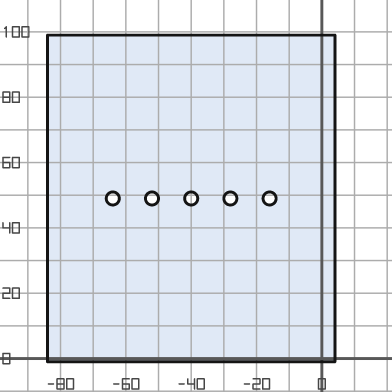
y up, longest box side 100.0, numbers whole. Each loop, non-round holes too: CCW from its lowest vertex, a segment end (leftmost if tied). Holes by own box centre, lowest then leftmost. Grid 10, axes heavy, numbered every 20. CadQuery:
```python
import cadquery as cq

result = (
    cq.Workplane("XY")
    .moveTo(-84.0, -1.0)
    .lineTo(4.0, -1.0)
    .lineTo(4.0, 99.0)
    .lineTo(-84.0, 99.0)
    .close()
    .moveTo(-64.0, 49.0)
    .circle(2.0)
    .moveTo(-52.0, 49.0)
    .circle(2.0)
    .moveTo(-40.0, 49.0)
    .circle(2.0)
    .moveTo(-28.0, 49.0)
    .circle(2.0)
    .moveTo(-16.0, 49.0)
    .circle(2.0)
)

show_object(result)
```